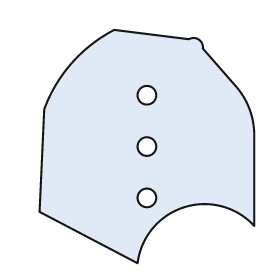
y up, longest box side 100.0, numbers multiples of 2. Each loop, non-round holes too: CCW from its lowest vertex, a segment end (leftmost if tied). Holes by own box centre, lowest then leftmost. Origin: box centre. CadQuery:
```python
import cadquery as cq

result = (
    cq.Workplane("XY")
    .moveTo(-4.0, -50.0)
    .threePointArc((16.0, -26.0), (46.0, -34.0))
    .lineTo(46.0, 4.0)
    .threePointArc((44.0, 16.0), (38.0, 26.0))
    .lineTo(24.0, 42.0)
    .threePointArc((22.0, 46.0), (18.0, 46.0))
    .lineTo(-14.0, 50.0)
    .threePointArc((-32.0, 36.0), (-44.0, 16.0))
    .lineTo(-46.0, -28.0)
    .close()
    .moveTo(0.0, -22.0)
    .circle(4.0)
    .moveTo(0.0, 0.0)
    .circle(4.0)
    .moveTo(0.0, 22.0)
    .circle(4.0)
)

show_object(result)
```